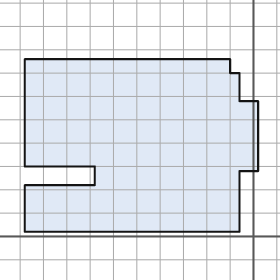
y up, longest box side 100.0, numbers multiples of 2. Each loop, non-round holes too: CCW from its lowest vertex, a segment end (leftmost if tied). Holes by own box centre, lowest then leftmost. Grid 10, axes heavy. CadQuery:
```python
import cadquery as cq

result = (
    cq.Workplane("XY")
    .moveTo(-98.0, 2.0)
    .lineTo(-6.0, 2.0)
    .lineTo(-6.0, 28.0)
    .lineTo(2.0, 28.0)
    .lineTo(2.0, 58.0)
    .lineTo(-6.0, 58.0)
    .lineTo(-6.0, 70.0)
    .lineTo(-10.0, 70.0)
    .lineTo(-10.0, 76.0)
    .lineTo(-98.0, 76.0)
    .lineTo(-98.0, 30.0)
    .lineTo(-68.0, 30.0)
    .lineTo(-68.0, 22.0)
    .lineTo(-98.0, 22.0)
    .close()
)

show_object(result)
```